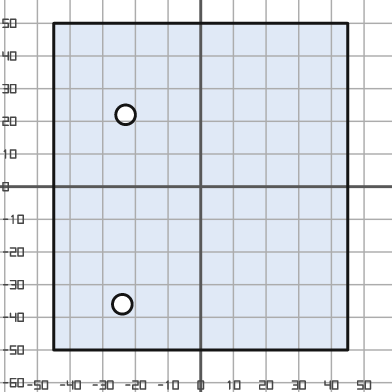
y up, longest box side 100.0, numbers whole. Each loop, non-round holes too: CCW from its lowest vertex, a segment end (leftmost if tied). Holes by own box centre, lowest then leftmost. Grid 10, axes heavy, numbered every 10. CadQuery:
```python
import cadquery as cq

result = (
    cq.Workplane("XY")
    .moveTo(-45.0, -50.0)
    .lineTo(45.0, -50.0)
    .lineTo(45.0, 50.0)
    .lineTo(-45.0, 50.0)
    .close()
    .moveTo(-24.0, -36.0)
    .circle(3.0)
    .moveTo(-23.0, 22.0)
    .circle(3.0)
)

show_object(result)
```